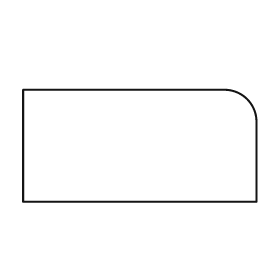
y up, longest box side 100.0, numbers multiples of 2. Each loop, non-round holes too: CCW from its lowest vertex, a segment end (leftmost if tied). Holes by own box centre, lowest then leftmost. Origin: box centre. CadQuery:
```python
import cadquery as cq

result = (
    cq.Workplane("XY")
    .moveTo(-50.0, -24.0)
    .lineTo(50.0, -24.0)
    .lineTo(50.0, 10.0)
    .threePointArc((46.0, 20.0), (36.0, 24.0))
    .lineTo(-50.0, 24.0)
    .close()
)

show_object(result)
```